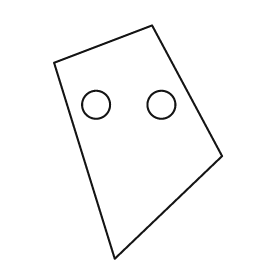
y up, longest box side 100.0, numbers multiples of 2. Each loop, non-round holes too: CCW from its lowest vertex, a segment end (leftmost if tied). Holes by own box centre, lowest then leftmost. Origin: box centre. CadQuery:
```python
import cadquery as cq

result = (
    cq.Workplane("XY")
    .moveTo(-10.0, -50.0)
    .lineTo(36.0, -6.0)
    .lineTo(6.0, 50.0)
    .lineTo(-36.0, 34.0)
    .close()
    .moveTo(-18.0, 16.0)
    .circle(6.0)
    .moveTo(10.0, 16.0)
    .circle(6.0)
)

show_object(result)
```